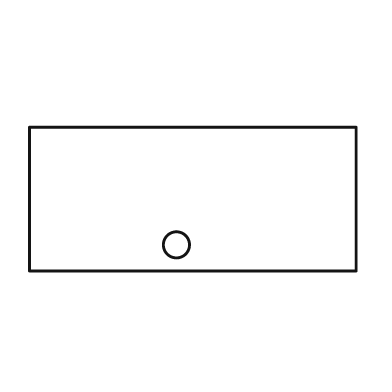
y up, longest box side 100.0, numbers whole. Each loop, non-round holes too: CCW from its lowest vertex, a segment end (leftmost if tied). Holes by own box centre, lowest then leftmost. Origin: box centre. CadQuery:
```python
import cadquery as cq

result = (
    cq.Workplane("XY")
    .moveTo(-50.0, -22.0)
    .lineTo(50.0, -22.0)
    .lineTo(50.0, 22.0)
    .lineTo(-50.0, 22.0)
    .close()
    .moveTo(-5.0, -14.0)
    .circle(4.0)
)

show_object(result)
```